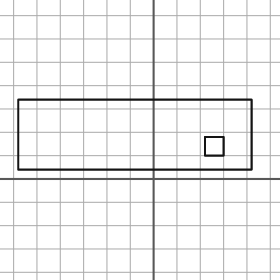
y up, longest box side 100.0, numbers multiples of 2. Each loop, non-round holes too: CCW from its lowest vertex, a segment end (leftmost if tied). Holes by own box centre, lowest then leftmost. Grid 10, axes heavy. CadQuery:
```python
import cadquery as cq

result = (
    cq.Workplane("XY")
    .moveTo(-58.0, 4.0)
    .lineTo(42.0, 4.0)
    .lineTo(42.0, 34.0)
    .lineTo(-58.0, 34.0)
    .close()
    .moveTo(22.0, 10.0)
    .lineTo(30.0, 10.0)
    .lineTo(30.0, 18.0)
    .lineTo(22.0, 18.0)
    .close()
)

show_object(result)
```